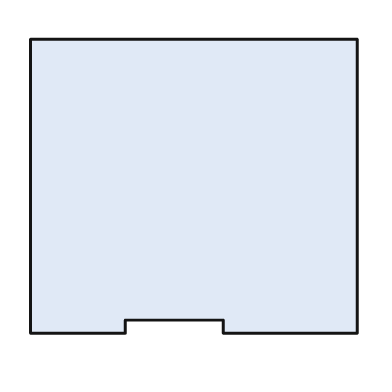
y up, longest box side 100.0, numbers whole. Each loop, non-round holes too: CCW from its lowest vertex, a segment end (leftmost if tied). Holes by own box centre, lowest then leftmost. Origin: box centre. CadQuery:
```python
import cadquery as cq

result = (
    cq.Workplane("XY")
    .moveTo(-50.0, -45.0)
    .lineTo(-21.0, -45.0)
    .lineTo(-21.0, -41.0)
    .lineTo(9.0, -41.0)
    .lineTo(9.0, -45.0)
    .lineTo(50.0, -45.0)
    .lineTo(50.0, 45.0)
    .lineTo(-50.0, 45.0)
    .close()
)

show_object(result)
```